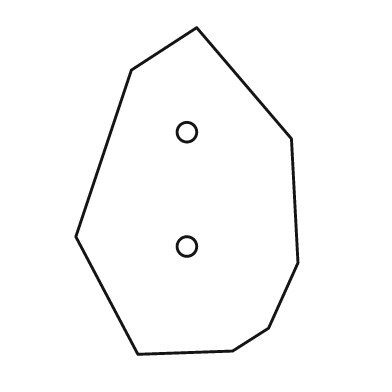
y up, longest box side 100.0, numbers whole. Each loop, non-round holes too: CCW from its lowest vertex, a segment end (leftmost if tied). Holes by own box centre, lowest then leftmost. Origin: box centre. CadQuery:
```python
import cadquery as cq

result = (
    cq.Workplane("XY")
    .moveTo(-15.0, -50.0)
    .lineTo(14.0, -49.0)
    .lineTo(25.0, -42.0)
    .lineTo(34.0, -22.0)
    .lineTo(32.0, 16.0)
    .lineTo(3.0, 50.0)
    .lineTo(-17.0, 37.0)
    .lineTo(-34.0, -14.0)
    .close()
    .moveTo(0.0, -17.0)
    .circle(3.0)
    .moveTo(0.0, 18.0)
    .circle(3.0)
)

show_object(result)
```